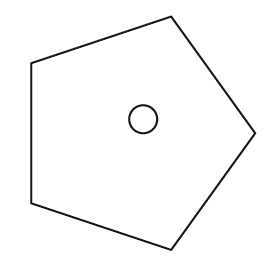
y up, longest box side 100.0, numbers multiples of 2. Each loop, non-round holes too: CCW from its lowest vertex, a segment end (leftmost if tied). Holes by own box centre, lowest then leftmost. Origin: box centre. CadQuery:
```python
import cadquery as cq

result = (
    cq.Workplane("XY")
    .moveTo(12.0, -50.0)
    .lineTo(48.0, 0.0)
    .lineTo(12.0, 50.0)
    .lineTo(-48.0, 30.0)
    .lineTo(-48.0, -30.0)
    .close()
    .moveTo(0.0, 6.0)
    .circle(6.0)
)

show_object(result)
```